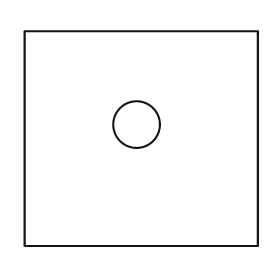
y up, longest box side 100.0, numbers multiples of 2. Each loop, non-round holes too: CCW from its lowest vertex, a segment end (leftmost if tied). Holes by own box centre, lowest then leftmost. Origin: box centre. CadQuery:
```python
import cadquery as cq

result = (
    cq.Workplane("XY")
    .moveTo(-50.0, -46.0)
    .lineTo(50.0, -46.0)
    .lineTo(50.0, 46.0)
    .lineTo(-50.0, 46.0)
    .close()
    .moveTo(-2.0, 6.0)
    .circle(10.0)
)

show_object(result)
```